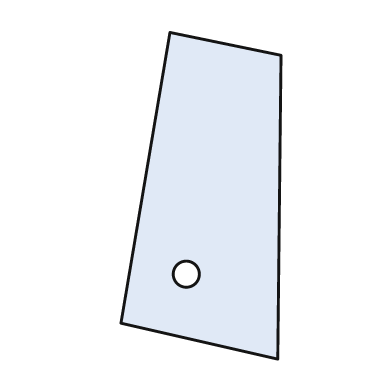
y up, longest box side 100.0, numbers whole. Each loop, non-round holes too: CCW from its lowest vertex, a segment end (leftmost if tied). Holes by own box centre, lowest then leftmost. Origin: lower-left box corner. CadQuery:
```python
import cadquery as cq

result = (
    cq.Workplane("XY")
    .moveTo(48.0, 0.0)
    .lineTo(49.0, 93.0)
    .lineTo(15.0, 100.0)
    .lineTo(0.0, 11.0)
    .close()
    .moveTo(20.0, 26.0)
    .circle(4.0)
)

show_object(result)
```